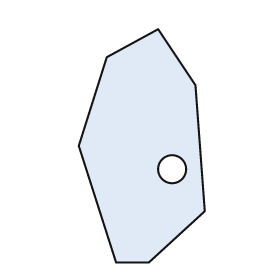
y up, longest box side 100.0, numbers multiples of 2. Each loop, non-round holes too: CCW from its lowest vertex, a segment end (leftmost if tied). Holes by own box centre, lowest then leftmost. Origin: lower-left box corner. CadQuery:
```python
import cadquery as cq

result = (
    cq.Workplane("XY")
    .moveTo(16.0, 0.0)
    .lineTo(30.0, 0.0)
    .lineTo(54.0, 22.0)
    .lineTo(50.0, 76.0)
    .lineTo(34.0, 100.0)
    .lineTo(12.0, 88.0)
    .lineTo(0.0, 50.0)
    .close()
    .moveTo(40.0, 40.0)
    .circle(6.0)
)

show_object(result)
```